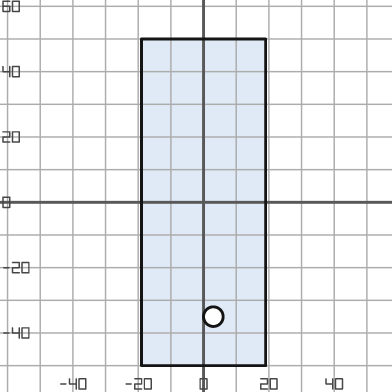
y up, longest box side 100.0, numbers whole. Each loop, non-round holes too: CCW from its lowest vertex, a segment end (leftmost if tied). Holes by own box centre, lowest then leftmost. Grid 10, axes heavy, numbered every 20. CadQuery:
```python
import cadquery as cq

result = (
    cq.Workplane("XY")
    .moveTo(-19.0, -50.0)
    .lineTo(19.0, -50.0)
    .lineTo(19.0, 50.0)
    .lineTo(-19.0, 50.0)
    .close()
    .moveTo(3.0, -35.0)
    .circle(3.0)
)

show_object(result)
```